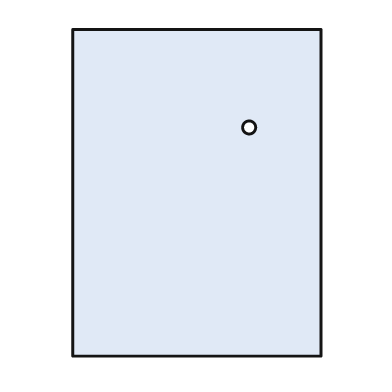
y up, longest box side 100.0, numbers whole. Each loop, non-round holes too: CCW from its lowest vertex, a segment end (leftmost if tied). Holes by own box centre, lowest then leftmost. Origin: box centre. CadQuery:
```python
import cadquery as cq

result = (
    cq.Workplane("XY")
    .moveTo(-38.0, -50.0)
    .lineTo(38.0, -50.0)
    .lineTo(38.0, 50.0)
    .lineTo(-38.0, 50.0)
    .close()
    .moveTo(16.0, 20.0)
    .circle(2.0)
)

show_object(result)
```